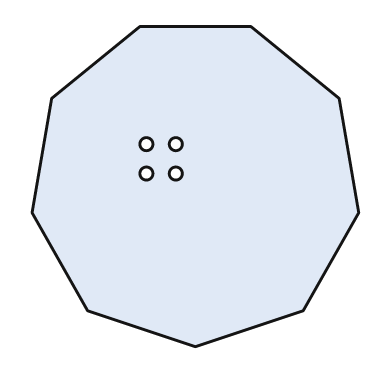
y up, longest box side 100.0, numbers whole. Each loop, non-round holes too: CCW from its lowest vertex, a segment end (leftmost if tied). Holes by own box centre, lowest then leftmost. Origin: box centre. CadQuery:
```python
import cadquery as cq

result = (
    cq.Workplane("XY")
    .moveTo(0.0, -49.0)
    .lineTo(33.0, -38.0)
    .lineTo(50.0, -8.0)
    .lineTo(44.0, 27.0)
    .lineTo(17.0, 49.0)
    .lineTo(-17.0, 49.0)
    .lineTo(-44.0, 27.0)
    .lineTo(-50.0, -8.0)
    .lineTo(-33.0, -38.0)
    .close()
    .moveTo(-15.0, 4.0)
    .circle(2.0)
    .moveTo(-6.0, 4.0)
    .circle(2.0)
    .moveTo(-15.0, 13.0)
    .circle(2.0)
    .moveTo(-6.0, 13.0)
    .circle(2.0)
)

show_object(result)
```